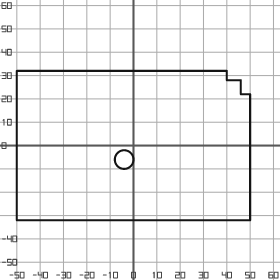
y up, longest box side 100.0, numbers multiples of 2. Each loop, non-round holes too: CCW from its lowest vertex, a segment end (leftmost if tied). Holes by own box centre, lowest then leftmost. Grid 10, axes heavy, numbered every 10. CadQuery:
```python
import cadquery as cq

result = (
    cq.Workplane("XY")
    .moveTo(-50.0, -32.0)
    .lineTo(50.0, -32.0)
    .lineTo(50.0, 22.0)
    .lineTo(46.0, 22.0)
    .lineTo(46.0, 28.0)
    .lineTo(40.0, 28.0)
    .lineTo(40.0, 32.0)
    .lineTo(-50.0, 32.0)
    .close()
    .moveTo(-4.0, -6.0)
    .circle(4.0)
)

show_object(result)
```